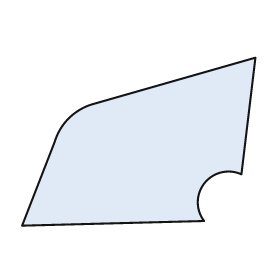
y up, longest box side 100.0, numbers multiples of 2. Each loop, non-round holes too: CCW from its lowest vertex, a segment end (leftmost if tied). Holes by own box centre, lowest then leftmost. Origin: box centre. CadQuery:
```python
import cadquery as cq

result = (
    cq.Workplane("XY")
    .moveTo(-50.0, -36.0)
    .lineTo(28.0, -34.0)
    .threePointArc((28.0, -18.0), (44.0, -14.0))
    .lineTo(50.0, 36.0)
    .lineTo(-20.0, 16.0)
    .threePointArc((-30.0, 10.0), (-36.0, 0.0))
    .close()
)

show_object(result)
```